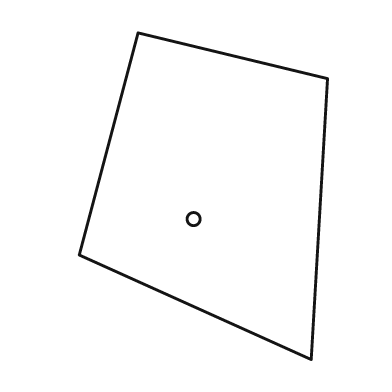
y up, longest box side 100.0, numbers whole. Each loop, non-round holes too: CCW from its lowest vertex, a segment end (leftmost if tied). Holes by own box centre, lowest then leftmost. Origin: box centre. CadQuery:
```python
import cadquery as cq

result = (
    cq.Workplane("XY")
    .moveTo(33.0, -50.0)
    .lineTo(38.0, 36.0)
    .lineTo(-20.0, 50.0)
    .lineTo(-38.0, -18.0)
    .close()
    .moveTo(-3.0, -7.0)
    .circle(2.0)
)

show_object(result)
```